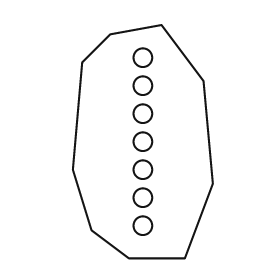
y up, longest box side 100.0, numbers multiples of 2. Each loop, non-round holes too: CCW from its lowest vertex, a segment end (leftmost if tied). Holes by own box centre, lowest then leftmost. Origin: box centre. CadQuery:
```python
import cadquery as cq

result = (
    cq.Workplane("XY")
    .moveTo(-6.0, -50.0)
    .lineTo(18.0, -50.0)
    .lineTo(30.0, -18.0)
    .lineTo(26.0, 26.0)
    .lineTo(8.0, 50.0)
    .lineTo(-14.0, 46.0)
    .lineTo(-26.0, 34.0)
    .lineTo(-30.0, -12.0)
    .lineTo(-22.0, -38.0)
    .close()
    .moveTo(0.0, -36.0)
    .circle(4.0)
    .moveTo(0.0, -24.0)
    .circle(4.0)
    .moveTo(0.0, -12.0)
    .circle(4.0)
    .moveTo(0.0, 0.0)
    .circle(4.0)
    .moveTo(0.0, 12.0)
    .circle(4.0)
    .moveTo(0.0, 24.0)
    .circle(4.0)
    .moveTo(0.0, 36.0)
    .circle(4.0)
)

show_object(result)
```